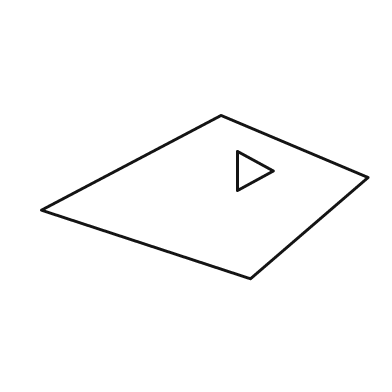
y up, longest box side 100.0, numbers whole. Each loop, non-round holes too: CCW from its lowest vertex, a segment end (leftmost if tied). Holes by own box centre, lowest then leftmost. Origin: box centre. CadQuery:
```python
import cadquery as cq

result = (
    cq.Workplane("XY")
    .moveTo(14.0, -25.0)
    .lineTo(50.0, 6.0)
    .lineTo(5.0, 25.0)
    .lineTo(-50.0, -4.0)
    .close()
    .moveTo(10.0, 2.0)
    .lineTo(21.0, 8.0)
    .lineTo(10.0, 14.0)
    .close()
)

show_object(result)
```